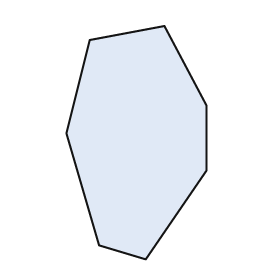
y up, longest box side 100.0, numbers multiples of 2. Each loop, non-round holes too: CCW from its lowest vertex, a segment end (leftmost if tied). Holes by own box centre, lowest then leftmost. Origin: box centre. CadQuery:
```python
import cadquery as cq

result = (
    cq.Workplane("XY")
    .moveTo(4.0, -50.0)
    .lineTo(30.0, -12.0)
    .lineTo(30.0, 16.0)
    .lineTo(12.0, 50.0)
    .lineTo(-20.0, 44.0)
    .lineTo(-30.0, 4.0)
    .lineTo(-16.0, -44.0)
    .close()
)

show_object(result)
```